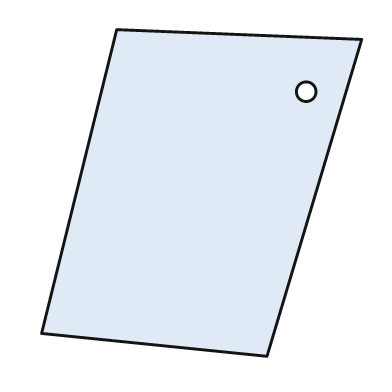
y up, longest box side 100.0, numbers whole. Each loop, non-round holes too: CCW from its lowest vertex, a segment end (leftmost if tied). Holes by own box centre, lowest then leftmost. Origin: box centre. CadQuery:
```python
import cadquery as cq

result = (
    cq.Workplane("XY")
    .moveTo(20.0, -50.0)
    .lineTo(49.0, 47.0)
    .lineTo(-26.0, 50.0)
    .lineTo(-49.0, -43.0)
    .close()
    .moveTo(32.0, 31.0)
    .circle(3.0)
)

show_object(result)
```